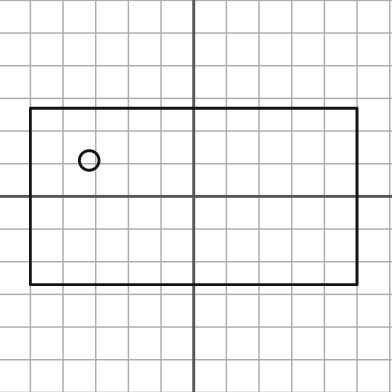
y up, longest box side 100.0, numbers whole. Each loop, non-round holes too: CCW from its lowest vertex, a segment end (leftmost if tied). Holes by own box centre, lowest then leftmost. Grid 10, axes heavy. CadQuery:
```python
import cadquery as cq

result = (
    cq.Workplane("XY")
    .moveTo(-50.0, -27.0)
    .lineTo(50.0, -27.0)
    .lineTo(50.0, 27.0)
    .lineTo(-50.0, 27.0)
    .close()
    .moveTo(-32.0, 11.0)
    .circle(3.0)
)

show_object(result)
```